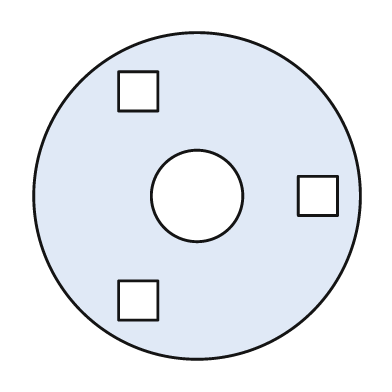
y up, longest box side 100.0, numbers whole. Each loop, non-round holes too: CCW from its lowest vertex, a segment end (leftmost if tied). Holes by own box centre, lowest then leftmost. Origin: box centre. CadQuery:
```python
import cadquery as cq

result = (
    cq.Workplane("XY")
    .moveTo(0.0, 0.0)
    .circle(50.0)
    .moveTo(-24.0, -38.0)
    .lineTo(-12.0, -38.0)
    .lineTo(-12.0, -26.0)
    .lineTo(-24.0, -26.0)
    .close()
    .moveTo(0.0, 0.0)
    .circle(14.0)
    .moveTo(31.0, -6.0)
    .lineTo(43.0, -6.0)
    .lineTo(43.0, 6.0)
    .lineTo(31.0, 6.0)
    .close()
    .moveTo(-24.0, 26.0)
    .lineTo(-12.0, 26.0)
    .lineTo(-12.0, 38.0)
    .lineTo(-24.0, 38.0)
    .close()
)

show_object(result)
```